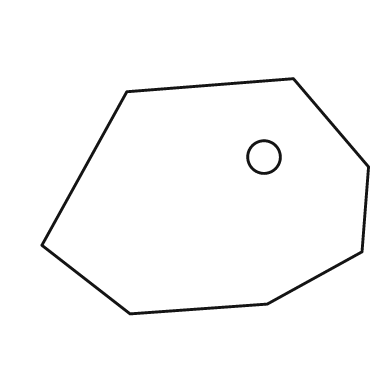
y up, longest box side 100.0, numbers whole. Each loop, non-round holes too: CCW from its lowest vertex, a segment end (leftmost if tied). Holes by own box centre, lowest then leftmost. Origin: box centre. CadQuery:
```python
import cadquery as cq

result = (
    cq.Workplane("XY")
    .moveTo(-23.0, -36.0)
    .lineTo(19.0, -33.0)
    .lineTo(48.0, -17.0)
    .lineTo(50.0, 9.0)
    .lineTo(27.0, 36.0)
    .lineTo(-24.0, 32.0)
    .lineTo(-50.0, -15.0)
    .close()
    .moveTo(18.0, 12.0)
    .circle(5.0)
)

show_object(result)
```